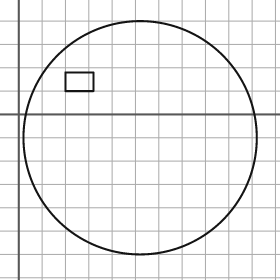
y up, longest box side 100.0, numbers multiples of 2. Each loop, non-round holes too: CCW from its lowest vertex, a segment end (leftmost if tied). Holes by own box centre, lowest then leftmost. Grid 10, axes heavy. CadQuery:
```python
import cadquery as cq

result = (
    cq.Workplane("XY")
    .moveTo(52.0, -10.0)
    .circle(50.0)
    .moveTo(20.0, 10.0)
    .lineTo(32.0, 10.0)
    .lineTo(32.0, 18.0)
    .lineTo(20.0, 18.0)
    .close()
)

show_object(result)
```